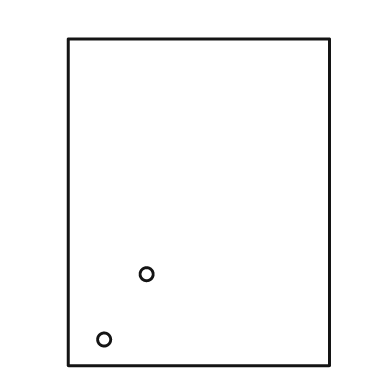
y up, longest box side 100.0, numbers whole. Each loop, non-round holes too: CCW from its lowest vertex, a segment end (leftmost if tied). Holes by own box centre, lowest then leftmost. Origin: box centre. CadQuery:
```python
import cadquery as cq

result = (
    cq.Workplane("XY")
    .moveTo(-40.0, -50.0)
    .lineTo(40.0, -50.0)
    .lineTo(40.0, 50.0)
    .lineTo(-40.0, 50.0)
    .close()
    .moveTo(-29.0, -42.0)
    .circle(2.0)
    .moveTo(-16.0, -22.0)
    .circle(2.0)
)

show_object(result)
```